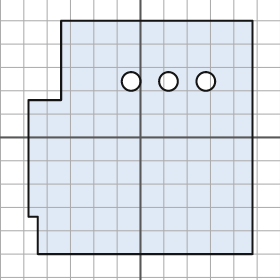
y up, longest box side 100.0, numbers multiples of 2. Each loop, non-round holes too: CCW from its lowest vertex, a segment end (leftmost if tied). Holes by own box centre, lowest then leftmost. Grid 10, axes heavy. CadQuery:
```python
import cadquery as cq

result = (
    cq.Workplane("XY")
    .moveTo(-44.0, -50.0)
    .lineTo(48.0, -50.0)
    .lineTo(48.0, 50.0)
    .lineTo(-34.0, 50.0)
    .lineTo(-34.0, 16.0)
    .lineTo(-48.0, 16.0)
    .lineTo(-48.0, -34.0)
    .lineTo(-44.0, -34.0)
    .close()
    .moveTo(-4.0, 24.0)
    .circle(4.0)
    .moveTo(12.0, 24.0)
    .circle(4.0)
    .moveTo(28.0, 24.0)
    .circle(4.0)
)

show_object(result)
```